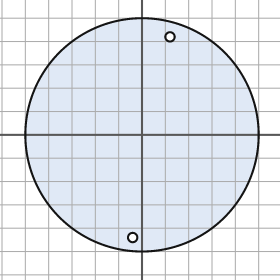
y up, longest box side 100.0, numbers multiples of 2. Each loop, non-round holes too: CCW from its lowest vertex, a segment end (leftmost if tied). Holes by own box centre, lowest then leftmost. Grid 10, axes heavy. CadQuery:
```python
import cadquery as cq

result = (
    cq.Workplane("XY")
    .moveTo(0.0, 0.0)
    .circle(50.0)
    .moveTo(-4.0, -44.0)
    .circle(2.0)
    .moveTo(12.0, 42.0)
    .circle(2.0)
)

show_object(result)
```